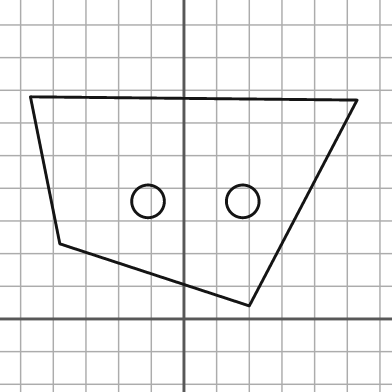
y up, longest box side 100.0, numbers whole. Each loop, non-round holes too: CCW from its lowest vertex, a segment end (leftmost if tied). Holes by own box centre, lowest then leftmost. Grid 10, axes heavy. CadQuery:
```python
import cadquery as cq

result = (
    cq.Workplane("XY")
    .moveTo(20.0, 4.0)
    .lineTo(53.0, 67.0)
    .lineTo(-47.0, 68.0)
    .lineTo(-38.0, 23.0)
    .close()
    .moveTo(-11.0, 36.0)
    .circle(5.0)
    .moveTo(18.0, 36.0)
    .circle(5.0)
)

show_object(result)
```